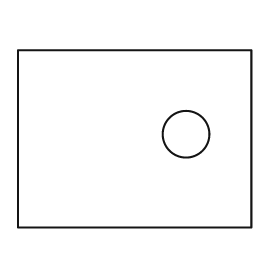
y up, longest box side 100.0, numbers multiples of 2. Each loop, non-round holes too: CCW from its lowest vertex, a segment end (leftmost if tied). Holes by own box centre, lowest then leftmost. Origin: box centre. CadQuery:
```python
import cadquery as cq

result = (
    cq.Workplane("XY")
    .moveTo(-50.0, -38.0)
    .lineTo(50.0, -38.0)
    .lineTo(50.0, 38.0)
    .lineTo(-50.0, 38.0)
    .close()
    .moveTo(22.0, 2.0)
    .circle(10.0)
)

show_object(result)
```